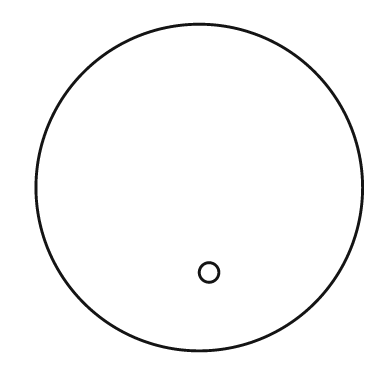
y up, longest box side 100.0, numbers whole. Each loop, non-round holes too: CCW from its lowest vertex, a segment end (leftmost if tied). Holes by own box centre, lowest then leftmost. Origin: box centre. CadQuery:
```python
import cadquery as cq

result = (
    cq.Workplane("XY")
    .moveTo(0.0, 0.0)
    .circle(50.0)
    .moveTo(3.0, -26.0)
    .circle(3.0)
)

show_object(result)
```